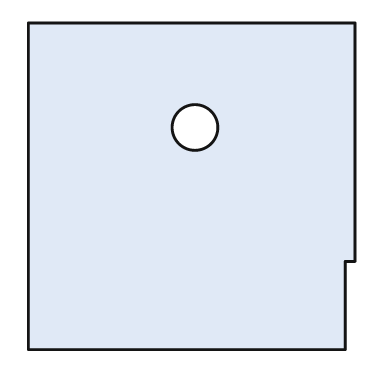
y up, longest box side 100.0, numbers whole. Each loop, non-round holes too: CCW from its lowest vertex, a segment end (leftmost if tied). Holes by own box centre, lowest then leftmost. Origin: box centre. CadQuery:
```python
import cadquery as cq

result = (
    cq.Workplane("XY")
    .moveTo(-50.0, -50.0)
    .lineTo(47.0, -50.0)
    .lineTo(47.0, -23.0)
    .lineTo(50.0, -23.0)
    .lineTo(50.0, 50.0)
    .lineTo(-50.0, 50.0)
    .close()
    .moveTo(1.0, 18.0)
    .circle(7.0)
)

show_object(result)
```